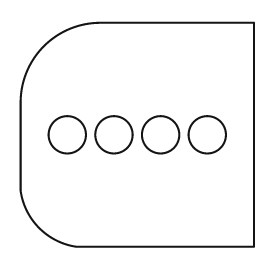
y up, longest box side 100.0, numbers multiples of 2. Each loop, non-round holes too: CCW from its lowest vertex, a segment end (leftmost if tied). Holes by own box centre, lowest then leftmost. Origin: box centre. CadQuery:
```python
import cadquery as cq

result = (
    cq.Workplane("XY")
    .moveTo(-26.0, -48.0)
    .lineTo(50.0, -48.0)
    .lineTo(50.0, 48.0)
    .lineTo(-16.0, 48.0)
    .threePointArc((-40.0, 38.0), (-50.0, 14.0))
    .lineTo(-50.0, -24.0)
    .threePointArc((-42.0, -40.0), (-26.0, -48.0))
    .close()
    .moveTo(-30.0, 0.0)
    .circle(8.0)
    .moveTo(-10.0, 0.0)
    .circle(8.0)
    .moveTo(10.0, 0.0)
    .circle(8.0)
    .moveTo(30.0, 0.0)
    .circle(8.0)
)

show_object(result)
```